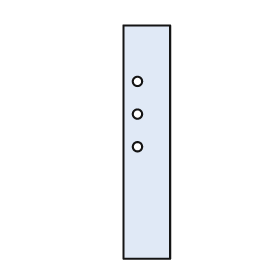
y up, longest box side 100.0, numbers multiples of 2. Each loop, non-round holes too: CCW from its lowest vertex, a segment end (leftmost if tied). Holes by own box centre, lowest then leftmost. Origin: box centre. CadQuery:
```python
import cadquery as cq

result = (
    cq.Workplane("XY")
    .moveTo(-10.0, -50.0)
    .lineTo(10.0, -50.0)
    .lineTo(10.0, 50.0)
    .lineTo(-10.0, 50.0)
    .close()
    .moveTo(-4.0, -2.0)
    .circle(2.0)
    .moveTo(-4.0, 12.0)
    .circle(2.0)
    .moveTo(-4.0, 26.0)
    .circle(2.0)
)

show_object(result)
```